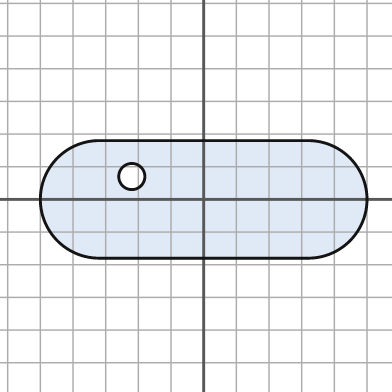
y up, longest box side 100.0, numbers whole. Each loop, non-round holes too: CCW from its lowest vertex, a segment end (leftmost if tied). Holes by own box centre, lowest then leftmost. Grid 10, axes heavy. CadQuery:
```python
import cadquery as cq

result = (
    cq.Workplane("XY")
    .moveTo(-32.0, -18.0)
    .lineTo(32.0, -18.0)
    .threePointArc((50.0, 0.0), (32.0, 18.0))
    .lineTo(-32.0, 18.0)
    .threePointArc((-50.0, 0.0), (-32.0, -18.0))
    .close()
    .moveTo(-22.0, 7.0)
    .circle(4.0)
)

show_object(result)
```